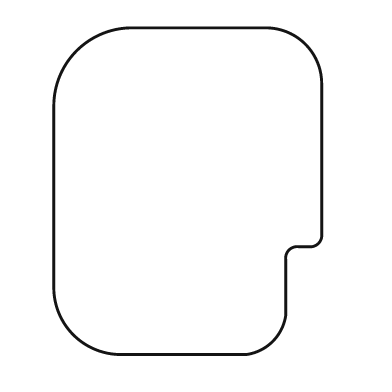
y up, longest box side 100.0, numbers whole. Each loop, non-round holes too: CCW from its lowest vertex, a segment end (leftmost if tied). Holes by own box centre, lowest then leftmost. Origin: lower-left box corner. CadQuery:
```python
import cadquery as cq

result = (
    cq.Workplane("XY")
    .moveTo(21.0, 0.0)
    .lineTo(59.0, 0.0)
    .threePointArc((67.0, 4.0), (71.0, 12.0))
    .lineTo(71.0, 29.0)
    .threePointArc((72.0, 32.0), (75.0, 33.0))
    .lineTo(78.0, 33.0)
    .threePointArc((81.0, 34.0), (82.0, 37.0))
    .lineTo(82.0, 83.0)
    .threePointArc((77.0, 95.0), (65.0, 100.0))
    .lineTo(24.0, 100.0)
    .threePointArc((7.0, 93.0), (0.0, 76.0))
    .lineTo(0.0, 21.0)
    .threePointArc((6.0, 6.0), (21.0, 0.0))
    .close()
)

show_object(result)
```